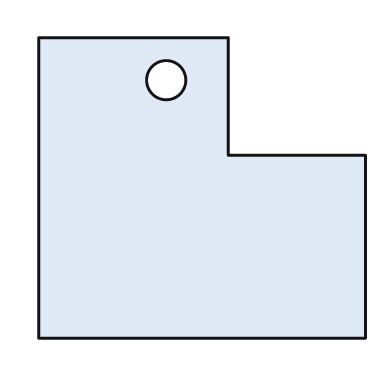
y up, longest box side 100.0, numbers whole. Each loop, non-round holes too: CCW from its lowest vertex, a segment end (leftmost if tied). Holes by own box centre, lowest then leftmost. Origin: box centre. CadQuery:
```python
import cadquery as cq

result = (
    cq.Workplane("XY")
    .moveTo(-50.0, -46.0)
    .lineTo(50.0, -46.0)
    .lineTo(50.0, 10.0)
    .lineTo(8.0, 10.0)
    .lineTo(8.0, 46.0)
    .lineTo(-50.0, 46.0)
    .close()
    .moveTo(-11.0, 33.0)
    .circle(6.0)
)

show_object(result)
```